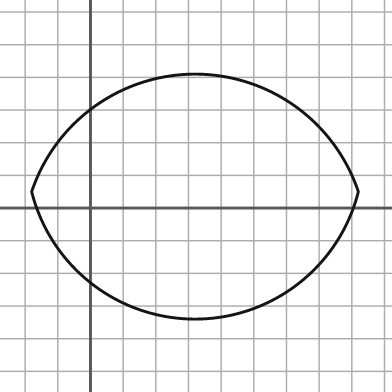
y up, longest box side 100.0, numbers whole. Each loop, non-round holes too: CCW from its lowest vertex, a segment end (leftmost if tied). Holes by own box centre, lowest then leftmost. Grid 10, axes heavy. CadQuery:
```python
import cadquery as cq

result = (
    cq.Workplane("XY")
    .moveTo(-18.0, 5.0)
    .threePointArc((32.0, -34.0), (82.0, 5.0))
    .threePointArc((32.0, 41.0), (-18.0, 5.0))
    .close()
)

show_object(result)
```